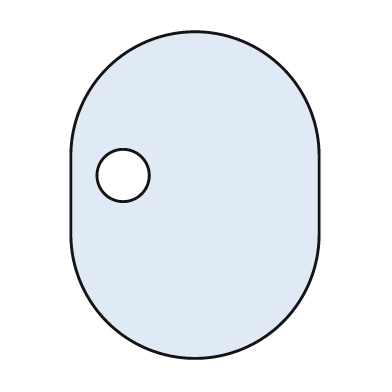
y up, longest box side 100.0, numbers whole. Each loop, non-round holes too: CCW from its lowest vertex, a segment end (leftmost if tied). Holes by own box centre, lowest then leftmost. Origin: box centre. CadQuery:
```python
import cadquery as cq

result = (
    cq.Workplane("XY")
    .moveTo(-38.0, -12.0)
    .threePointArc((0.0, -50.0), (38.0, -12.0))
    .lineTo(38.0, 12.0)
    .threePointArc((0.0, 50.0), (-38.0, 12.0))
    .close()
    .moveTo(-22.0, 6.0)
    .circle(8.0)
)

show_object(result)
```